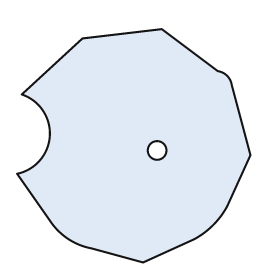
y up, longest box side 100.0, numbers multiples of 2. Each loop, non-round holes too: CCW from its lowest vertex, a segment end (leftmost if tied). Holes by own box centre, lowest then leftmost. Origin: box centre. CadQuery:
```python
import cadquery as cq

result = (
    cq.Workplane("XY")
    .moveTo(4.0, -50.0)
    .lineTo(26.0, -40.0)
    .threePointArc((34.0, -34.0), (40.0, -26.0))
    .lineTo(50.0, -4.0)
    .lineTo(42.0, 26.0)
    .threePointArc((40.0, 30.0), (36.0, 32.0))
    .lineTo(12.0, 50.0)
    .lineTo(-22.0, 46.0)
    .lineTo(-48.0, 22.0)
    .threePointArc((-36.0, 4.0), (-50.0, -12.0))
    .lineTo(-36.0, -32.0)
    .threePointArc((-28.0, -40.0), (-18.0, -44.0))
    .close()
    .moveTo(10.0, -2.0)
    .circle(4.0)
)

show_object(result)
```